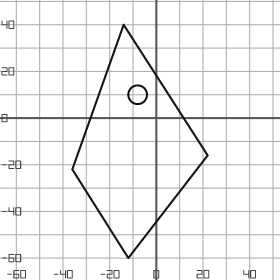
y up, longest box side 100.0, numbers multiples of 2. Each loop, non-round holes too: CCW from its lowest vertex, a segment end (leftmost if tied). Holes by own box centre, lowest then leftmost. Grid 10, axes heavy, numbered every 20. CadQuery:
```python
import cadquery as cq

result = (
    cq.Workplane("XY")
    .moveTo(-12.0, -60.0)
    .lineTo(22.0, -16.0)
    .lineTo(-14.0, 40.0)
    .lineTo(-36.0, -22.0)
    .close()
    .moveTo(-8.0, 10.0)
    .circle(4.0)
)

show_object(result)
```